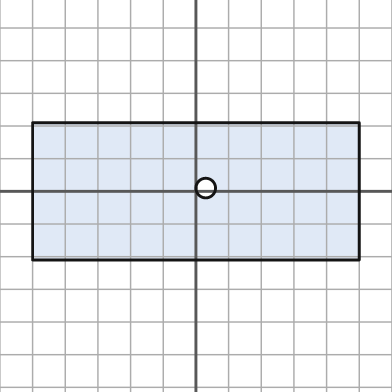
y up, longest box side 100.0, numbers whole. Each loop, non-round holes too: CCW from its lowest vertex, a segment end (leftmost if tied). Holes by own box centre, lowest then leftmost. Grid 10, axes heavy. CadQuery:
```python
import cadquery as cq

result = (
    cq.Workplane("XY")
    .moveTo(-50.0, -21.0)
    .lineTo(50.0, -21.0)
    .lineTo(50.0, 21.0)
    .lineTo(-50.0, 21.0)
    .close()
    .moveTo(3.0, 1.0)
    .circle(3.0)
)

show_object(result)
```